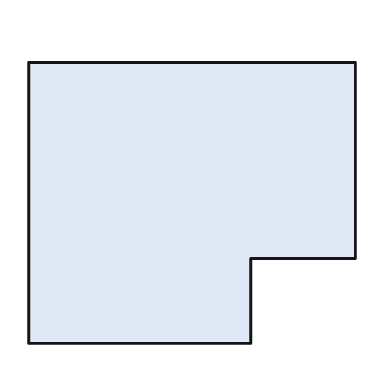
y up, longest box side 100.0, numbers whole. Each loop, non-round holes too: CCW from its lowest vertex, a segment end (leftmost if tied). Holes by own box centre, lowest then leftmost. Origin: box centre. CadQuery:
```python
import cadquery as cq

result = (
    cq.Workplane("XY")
    .moveTo(-50.0, -43.0)
    .lineTo(18.0, -43.0)
    .lineTo(18.0, -17.0)
    .lineTo(50.0, -17.0)
    .lineTo(50.0, 43.0)
    .lineTo(-50.0, 43.0)
    .close()
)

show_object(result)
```